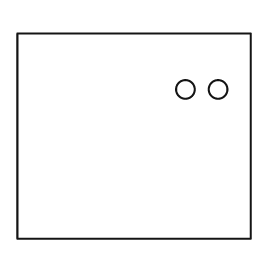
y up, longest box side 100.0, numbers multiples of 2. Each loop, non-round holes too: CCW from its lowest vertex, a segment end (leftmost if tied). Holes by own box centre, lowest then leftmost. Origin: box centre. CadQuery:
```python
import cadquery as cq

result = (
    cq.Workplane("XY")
    .moveTo(-50.0, -44.0)
    .lineTo(50.0, -44.0)
    .lineTo(50.0, 44.0)
    .lineTo(-50.0, 44.0)
    .close()
    .moveTo(22.0, 20.0)
    .circle(4.0)
    .moveTo(36.0, 20.0)
    .circle(4.0)
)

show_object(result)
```